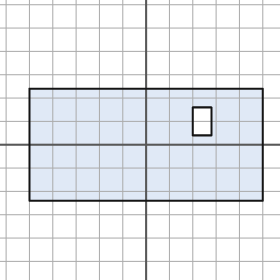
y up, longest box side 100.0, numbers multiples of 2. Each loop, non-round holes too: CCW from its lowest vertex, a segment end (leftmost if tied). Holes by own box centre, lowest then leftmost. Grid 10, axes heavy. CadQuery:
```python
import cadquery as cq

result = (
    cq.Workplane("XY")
    .moveTo(-50.0, -24.0)
    .lineTo(50.0, -24.0)
    .lineTo(50.0, 24.0)
    .lineTo(-50.0, 24.0)
    .close()
    .moveTo(20.0, 4.0)
    .lineTo(28.0, 4.0)
    .lineTo(28.0, 16.0)
    .lineTo(20.0, 16.0)
    .close()
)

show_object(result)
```